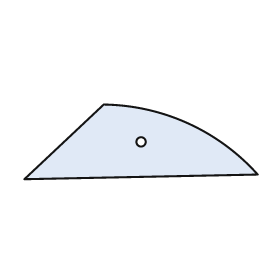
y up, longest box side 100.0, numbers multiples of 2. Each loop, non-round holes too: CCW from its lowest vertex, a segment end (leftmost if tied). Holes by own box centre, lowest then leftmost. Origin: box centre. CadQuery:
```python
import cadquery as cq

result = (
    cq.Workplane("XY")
    .moveTo(-50.0, -16.0)
    .lineTo(50.0, -14.0)
    .threePointArc((20.0, 8.0), (-16.0, 16.0))
    .close()
    .moveTo(0.0, 0.0)
    .circle(2.0)
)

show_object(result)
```